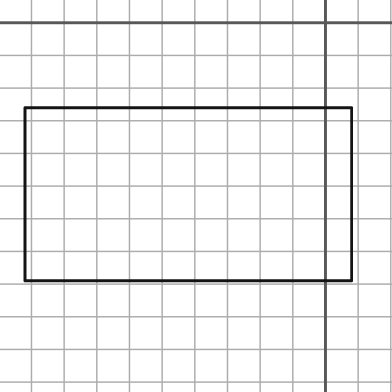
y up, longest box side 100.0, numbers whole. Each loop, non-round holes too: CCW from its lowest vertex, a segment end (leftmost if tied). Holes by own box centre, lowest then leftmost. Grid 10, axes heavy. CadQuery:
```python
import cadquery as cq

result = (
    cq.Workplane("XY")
    .moveTo(-92.0, -79.0)
    .lineTo(8.0, -79.0)
    .lineTo(8.0, -26.0)
    .lineTo(-92.0, -26.0)
    .close()
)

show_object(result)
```